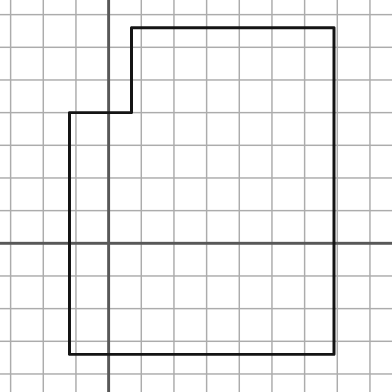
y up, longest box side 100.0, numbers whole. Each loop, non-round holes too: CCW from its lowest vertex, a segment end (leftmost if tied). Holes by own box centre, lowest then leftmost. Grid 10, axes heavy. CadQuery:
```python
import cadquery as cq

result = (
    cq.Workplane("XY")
    .moveTo(-12.0, -34.0)
    .lineTo(69.0, -34.0)
    .lineTo(69.0, 66.0)
    .lineTo(7.0, 66.0)
    .lineTo(7.0, 40.0)
    .lineTo(-12.0, 40.0)
    .close()
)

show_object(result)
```